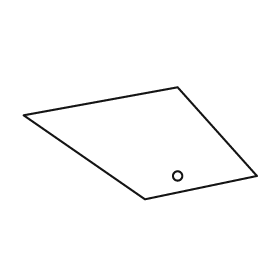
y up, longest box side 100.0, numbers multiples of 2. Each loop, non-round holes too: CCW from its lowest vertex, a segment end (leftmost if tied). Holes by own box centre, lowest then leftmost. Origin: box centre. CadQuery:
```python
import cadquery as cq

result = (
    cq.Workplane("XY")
    .moveTo(2.0, -24.0)
    .lineTo(50.0, -14.0)
    .lineTo(16.0, 24.0)
    .lineTo(-50.0, 12.0)
    .close()
    .moveTo(16.0, -14.0)
    .circle(2.0)
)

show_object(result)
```